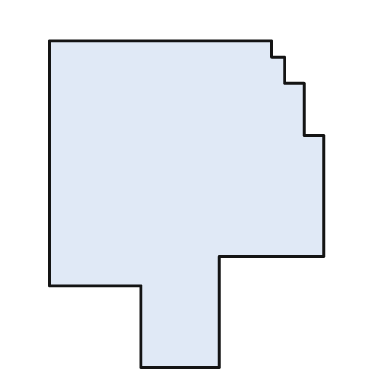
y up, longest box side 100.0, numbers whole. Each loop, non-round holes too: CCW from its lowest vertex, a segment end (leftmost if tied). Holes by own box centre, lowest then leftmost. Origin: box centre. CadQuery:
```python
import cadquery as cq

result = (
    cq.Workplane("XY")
    .moveTo(-14.0, -50.0)
    .lineTo(10.0, -50.0)
    .lineTo(10.0, -16.0)
    .lineTo(42.0, -16.0)
    .lineTo(42.0, 21.0)
    .lineTo(36.0, 21.0)
    .lineTo(36.0, 37.0)
    .lineTo(30.0, 37.0)
    .lineTo(30.0, 45.0)
    .lineTo(26.0, 45.0)
    .lineTo(26.0, 50.0)
    .lineTo(-42.0, 50.0)
    .lineTo(-42.0, -25.0)
    .lineTo(-14.0, -25.0)
    .close()
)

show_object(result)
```